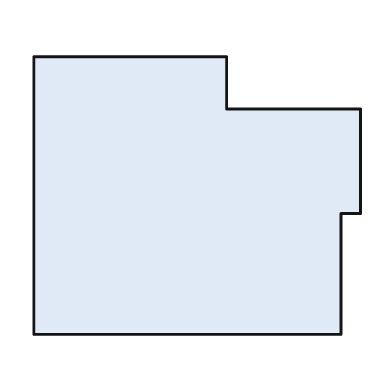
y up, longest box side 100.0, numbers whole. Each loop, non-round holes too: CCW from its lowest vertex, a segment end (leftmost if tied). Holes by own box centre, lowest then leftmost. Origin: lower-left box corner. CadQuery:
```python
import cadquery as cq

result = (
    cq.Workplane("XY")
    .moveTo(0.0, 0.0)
    .lineTo(94.0, 0.0)
    .lineTo(94.0, 37.0)
    .lineTo(100.0, 37.0)
    .lineTo(100.0, 69.0)
    .lineTo(59.0, 69.0)
    .lineTo(59.0, 85.0)
    .lineTo(0.0, 85.0)
    .close()
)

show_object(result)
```